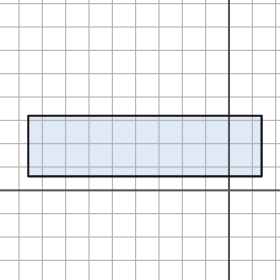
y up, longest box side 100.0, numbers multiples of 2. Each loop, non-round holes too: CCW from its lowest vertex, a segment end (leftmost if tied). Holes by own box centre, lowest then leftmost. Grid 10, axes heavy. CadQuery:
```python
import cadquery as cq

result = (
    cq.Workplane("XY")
    .moveTo(-86.0, 6.0)
    .lineTo(14.0, 6.0)
    .lineTo(14.0, 32.0)
    .lineTo(-86.0, 32.0)
    .close()
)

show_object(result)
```